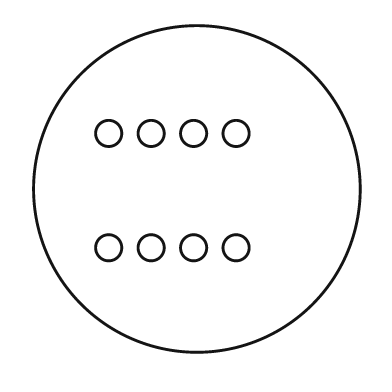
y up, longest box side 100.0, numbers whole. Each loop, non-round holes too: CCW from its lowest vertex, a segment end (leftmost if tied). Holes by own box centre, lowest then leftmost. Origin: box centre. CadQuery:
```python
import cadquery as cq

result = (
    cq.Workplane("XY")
    .moveTo(0.0, 0.0)
    .circle(50.0)
    .moveTo(-27.0, -18.0)
    .circle(4.0)
    .moveTo(-14.0, -18.0)
    .circle(4.0)
    .moveTo(-1.0, -18.0)
    .circle(4.0)
    .moveTo(12.0, -18.0)
    .circle(4.0)
    .moveTo(-27.0, 17.0)
    .circle(4.0)
    .moveTo(-14.0, 17.0)
    .circle(4.0)
    .moveTo(-1.0, 17.0)
    .circle(4.0)
    .moveTo(12.0, 17.0)
    .circle(4.0)
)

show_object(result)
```